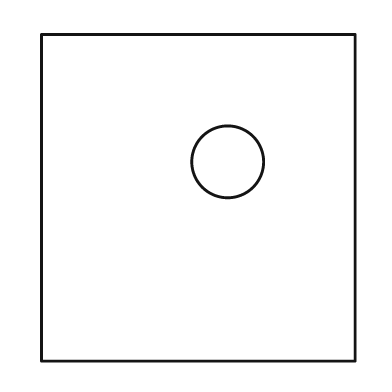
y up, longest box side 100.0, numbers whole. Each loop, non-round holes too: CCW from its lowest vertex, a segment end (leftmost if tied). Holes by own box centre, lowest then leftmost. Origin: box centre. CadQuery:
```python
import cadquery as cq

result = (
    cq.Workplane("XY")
    .moveTo(-48.0, -50.0)
    .lineTo(48.0, -50.0)
    .lineTo(48.0, 50.0)
    .lineTo(-48.0, 50.0)
    .close()
    .moveTo(9.0, 11.0)
    .circle(11.0)
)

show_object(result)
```